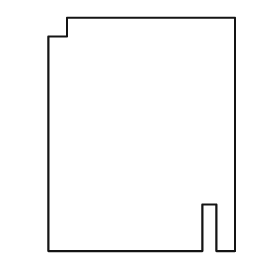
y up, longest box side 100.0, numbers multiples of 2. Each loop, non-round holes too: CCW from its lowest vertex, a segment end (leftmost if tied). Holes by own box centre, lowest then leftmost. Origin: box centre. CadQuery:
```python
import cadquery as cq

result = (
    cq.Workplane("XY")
    .moveTo(-40.0, -50.0)
    .lineTo(26.0, -50.0)
    .lineTo(26.0, -30.0)
    .lineTo(32.0, -30.0)
    .lineTo(32.0, -50.0)
    .lineTo(40.0, -50.0)
    .lineTo(40.0, 50.0)
    .lineTo(-32.0, 50.0)
    .lineTo(-32.0, 42.0)
    .lineTo(-40.0, 42.0)
    .close()
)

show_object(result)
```